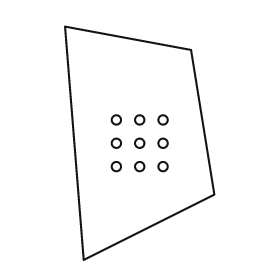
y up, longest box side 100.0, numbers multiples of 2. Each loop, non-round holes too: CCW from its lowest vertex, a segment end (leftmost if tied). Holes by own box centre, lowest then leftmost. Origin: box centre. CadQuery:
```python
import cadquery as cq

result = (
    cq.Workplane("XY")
    .moveTo(-24.0, -50.0)
    .lineTo(32.0, -22.0)
    .lineTo(22.0, 40.0)
    .lineTo(-32.0, 50.0)
    .close()
    .moveTo(-10.0, -10.0)
    .circle(2.0)
    .moveTo(0.0, -10.0)
    .circle(2.0)
    .moveTo(10.0, -10.0)
    .circle(2.0)
    .moveTo(-10.0, 0.0)
    .circle(2.0)
    .moveTo(0.0, 0.0)
    .circle(2.0)
    .moveTo(10.0, 0.0)
    .circle(2.0)
    .moveTo(-10.0, 10.0)
    .circle(2.0)
    .moveTo(0.0, 10.0)
    .circle(2.0)
    .moveTo(10.0, 10.0)
    .circle(2.0)
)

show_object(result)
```